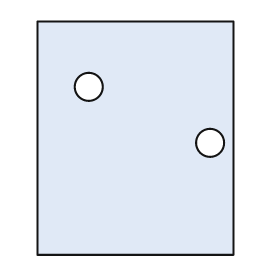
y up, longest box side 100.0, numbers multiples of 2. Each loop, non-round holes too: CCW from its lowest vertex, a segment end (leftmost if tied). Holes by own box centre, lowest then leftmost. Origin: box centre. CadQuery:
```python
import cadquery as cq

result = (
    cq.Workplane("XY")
    .moveTo(-42.0, -50.0)
    .lineTo(42.0, -50.0)
    .lineTo(42.0, 50.0)
    .lineTo(-42.0, 50.0)
    .close()
    .moveTo(32.0, -2.0)
    .circle(6.0)
    .moveTo(-20.0, 22.0)
    .circle(6.0)
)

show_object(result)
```